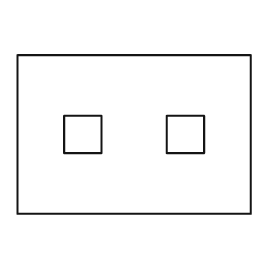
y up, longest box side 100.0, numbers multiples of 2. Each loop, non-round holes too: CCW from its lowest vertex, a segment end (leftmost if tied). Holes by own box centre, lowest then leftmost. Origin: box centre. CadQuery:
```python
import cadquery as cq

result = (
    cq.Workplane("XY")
    .moveTo(-50.0, -34.0)
    .lineTo(50.0, -34.0)
    .lineTo(50.0, 34.0)
    .lineTo(-50.0, 34.0)
    .close()
    .moveTo(-30.0, -8.0)
    .lineTo(-14.0, -8.0)
    .lineTo(-14.0, 8.0)
    .lineTo(-30.0, 8.0)
    .close()
    .moveTo(14.0, -8.0)
    .lineTo(30.0, -8.0)
    .lineTo(30.0, 8.0)
    .lineTo(14.0, 8.0)
    .close()
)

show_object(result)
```